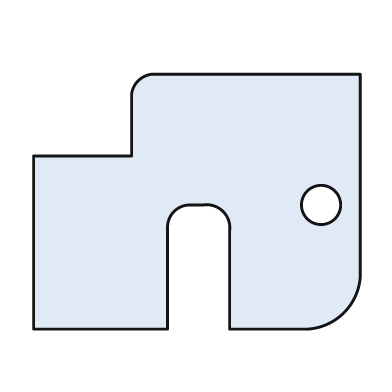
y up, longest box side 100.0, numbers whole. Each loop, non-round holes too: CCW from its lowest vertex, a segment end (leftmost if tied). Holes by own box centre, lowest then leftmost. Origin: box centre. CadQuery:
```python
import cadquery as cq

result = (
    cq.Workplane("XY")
    .moveTo(-50.0, -39.0)
    .lineTo(-9.0, -39.0)
    .lineTo(-9.0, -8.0)
    .threePointArc((-7.0, -3.0), (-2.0, -1.0))
    .lineTo(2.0, -1.0)
    .threePointArc((8.0, -3.0), (10.0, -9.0))
    .lineTo(10.0, -39.0)
    .lineTo(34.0, -39.0)
    .threePointArc((45.0, -34.0), (50.0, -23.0))
    .lineTo(50.0, 39.0)
    .lineTo(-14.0, 39.0)
    .threePointArc((-18.0, 37.0), (-20.0, 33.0))
    .lineTo(-20.0, 14.0)
    .lineTo(-50.0, 14.0)
    .close()
    .moveTo(38.0, -1.0)
    .circle(6.0)
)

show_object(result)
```